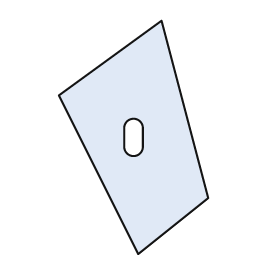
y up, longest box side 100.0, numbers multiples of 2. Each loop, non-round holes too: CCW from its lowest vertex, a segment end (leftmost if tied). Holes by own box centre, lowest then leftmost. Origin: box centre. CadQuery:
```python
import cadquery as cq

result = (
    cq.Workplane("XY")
    .moveTo(2.0, -50.0)
    .lineTo(32.0, -26.0)
    .lineTo(12.0, 50.0)
    .lineTo(-32.0, 18.0)
    .close()
    .moveTo(-4.0, -4.0)
    .threePointArc((0.0, -8.0), (4.0, -4.0))
    .lineTo(4.0, 4.0)
    .threePointArc((0.0, 8.0), (-4.0, 4.0))
    .close()
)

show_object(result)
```